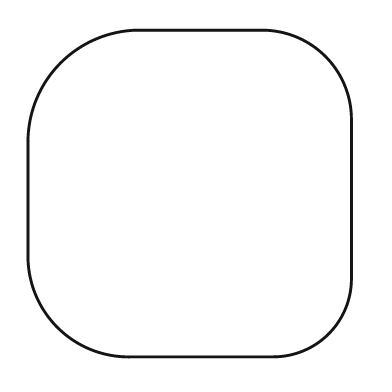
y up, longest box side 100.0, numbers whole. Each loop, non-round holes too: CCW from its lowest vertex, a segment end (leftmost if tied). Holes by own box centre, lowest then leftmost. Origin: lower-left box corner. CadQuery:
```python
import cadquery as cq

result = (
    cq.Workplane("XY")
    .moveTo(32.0, 0.0)
    .lineTo(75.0, 0.0)
    .threePointArc((92.0, 7.0), (99.0, 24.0))
    .lineTo(99.0, 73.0)
    .threePointArc((91.0, 92.0), (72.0, 100.0))
    .lineTo(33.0, 100.0)
    .threePointArc((10.0, 90.0), (0.0, 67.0))
    .lineTo(0.0, 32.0)
    .threePointArc((9.0, 9.0), (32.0, 0.0))
    .close()
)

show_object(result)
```